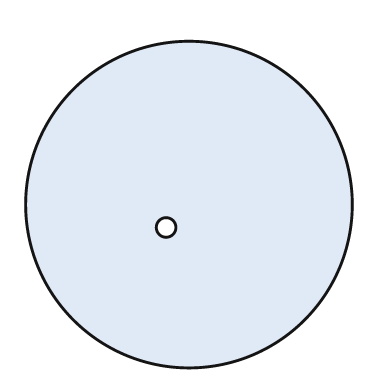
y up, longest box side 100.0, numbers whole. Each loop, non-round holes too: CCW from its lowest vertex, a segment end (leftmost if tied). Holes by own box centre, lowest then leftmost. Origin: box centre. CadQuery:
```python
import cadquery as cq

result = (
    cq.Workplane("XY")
    .moveTo(0.0, 0.0)
    .circle(50.0)
    .moveTo(-7.0, -7.0)
    .circle(3.0)
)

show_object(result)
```